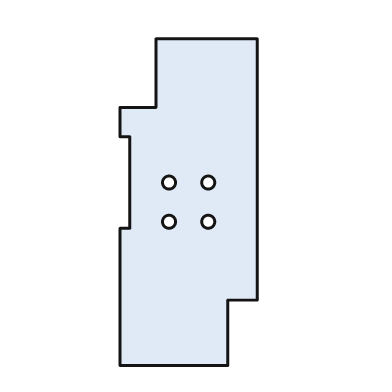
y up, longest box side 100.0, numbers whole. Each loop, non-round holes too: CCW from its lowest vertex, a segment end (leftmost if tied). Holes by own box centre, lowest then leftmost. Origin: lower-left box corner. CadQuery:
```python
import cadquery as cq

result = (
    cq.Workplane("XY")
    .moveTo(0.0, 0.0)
    .lineTo(33.0, 0.0)
    .lineTo(33.0, 20.0)
    .lineTo(42.0, 20.0)
    .lineTo(42.0, 100.0)
    .lineTo(11.0, 100.0)
    .lineTo(11.0, 79.0)
    .lineTo(0.0, 79.0)
    .lineTo(0.0, 70.0)
    .lineTo(3.0, 70.0)
    .lineTo(3.0, 42.0)
    .lineTo(0.0, 42.0)
    .close()
    .moveTo(15.0, 44.0)
    .circle(2.0)
    .moveTo(27.0, 44.0)
    .circle(2.0)
    .moveTo(15.0, 56.0)
    .circle(2.0)
    .moveTo(27.0, 56.0)
    .circle(2.0)
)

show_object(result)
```